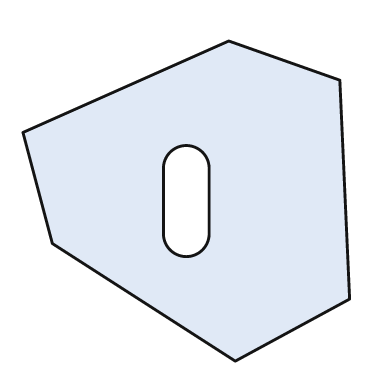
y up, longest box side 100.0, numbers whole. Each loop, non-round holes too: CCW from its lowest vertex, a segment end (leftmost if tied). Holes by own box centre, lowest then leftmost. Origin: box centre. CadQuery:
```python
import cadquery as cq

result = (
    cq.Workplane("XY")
    .moveTo(15.0, -49.0)
    .lineTo(50.0, -30.0)
    .lineTo(47.0, 37.0)
    .lineTo(13.0, 49.0)
    .lineTo(-50.0, 21.0)
    .lineTo(-41.0, -13.0)
    .close()
    .moveTo(-7.0, -10.0)
    .threePointArc((0.0, -17.0), (7.0, -10.0))
    .lineTo(7.0, 10.0)
    .threePointArc((0.0, 17.0), (-7.0, 10.0))
    .close()
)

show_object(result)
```